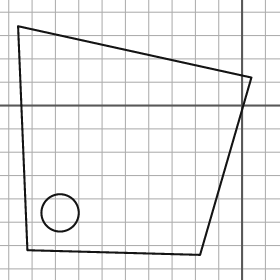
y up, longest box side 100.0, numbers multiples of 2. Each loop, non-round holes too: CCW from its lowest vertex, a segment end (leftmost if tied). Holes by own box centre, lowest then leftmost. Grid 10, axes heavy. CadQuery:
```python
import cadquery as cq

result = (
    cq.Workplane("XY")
    .moveTo(-18.0, -64.0)
    .lineTo(4.0, 12.0)
    .lineTo(-96.0, 34.0)
    .lineTo(-92.0, -62.0)
    .close()
    .moveTo(-78.0, -46.0)
    .circle(8.0)
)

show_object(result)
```